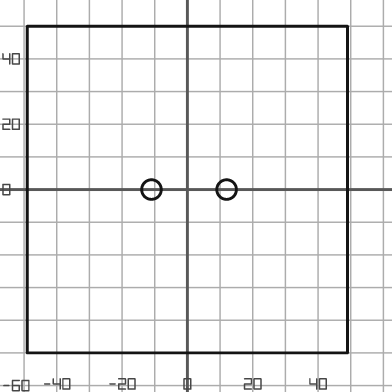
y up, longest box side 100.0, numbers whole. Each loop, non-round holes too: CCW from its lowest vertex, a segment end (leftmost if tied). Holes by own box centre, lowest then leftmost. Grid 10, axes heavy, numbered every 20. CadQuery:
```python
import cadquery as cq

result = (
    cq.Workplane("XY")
    .moveTo(-49.0, -50.0)
    .lineTo(49.0, -50.0)
    .lineTo(49.0, 50.0)
    .lineTo(-49.0, 50.0)
    .close()
    .moveTo(-11.0, 0.0)
    .circle(3.0)
    .moveTo(12.0, 0.0)
    .circle(3.0)
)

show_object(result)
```